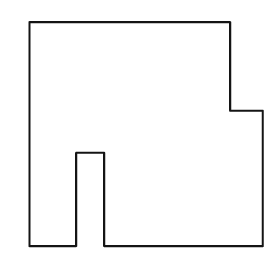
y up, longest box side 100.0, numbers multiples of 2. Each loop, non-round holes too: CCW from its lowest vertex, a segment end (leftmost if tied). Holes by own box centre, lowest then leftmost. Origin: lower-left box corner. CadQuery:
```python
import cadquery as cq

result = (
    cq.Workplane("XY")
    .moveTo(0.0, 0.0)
    .lineTo(20.0, 0.0)
    .lineTo(20.0, 40.0)
    .lineTo(32.0, 40.0)
    .lineTo(32.0, 0.0)
    .lineTo(100.0, 0.0)
    .lineTo(100.0, 58.0)
    .lineTo(86.0, 58.0)
    .lineTo(86.0, 96.0)
    .lineTo(0.0, 96.0)
    .close()
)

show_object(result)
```